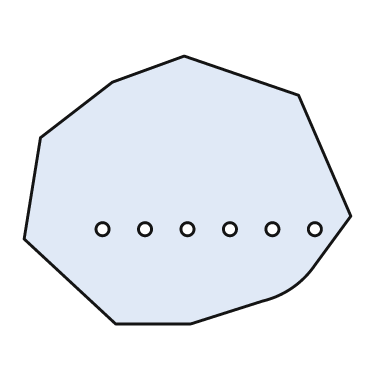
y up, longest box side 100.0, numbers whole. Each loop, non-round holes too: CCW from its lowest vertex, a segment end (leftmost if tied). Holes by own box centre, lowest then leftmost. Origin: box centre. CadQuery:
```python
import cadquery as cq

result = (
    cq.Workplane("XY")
    .moveTo(-22.0, -41.0)
    .lineTo(1.0, -41.0)
    .lineTo(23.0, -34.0)
    .threePointArc((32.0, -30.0), (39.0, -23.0))
    .lineTo(50.0, -8.0)
    .lineTo(34.0, 29.0)
    .lineTo(-1.0, 41.0)
    .lineTo(-23.0, 33.0)
    .lineTo(-45.0, 16.0)
    .lineTo(-50.0, -15.0)
    .close()
    .moveTo(-26.0, -12.0)
    .circle(2.0)
    .moveTo(-13.0, -12.0)
    .circle(2.0)
    .moveTo(0.0, -12.0)
    .circle(2.0)
    .moveTo(13.0, -12.0)
    .circle(2.0)
    .moveTo(26.0, -12.0)
    .circle(2.0)
    .moveTo(39.0, -12.0)
    .circle(2.0)
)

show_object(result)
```